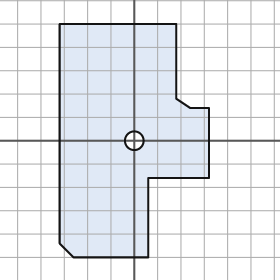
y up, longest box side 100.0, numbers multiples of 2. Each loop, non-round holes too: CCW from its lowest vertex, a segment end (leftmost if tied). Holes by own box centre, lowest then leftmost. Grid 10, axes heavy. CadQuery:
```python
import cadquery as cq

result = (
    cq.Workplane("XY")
    .moveTo(-26.0, -50.0)
    .lineTo(6.0, -50.0)
    .lineTo(6.0, -16.0)
    .lineTo(32.0, -16.0)
    .lineTo(32.0, 14.0)
    .lineTo(24.0, 14.0)
    .lineTo(18.0, 18.0)
    .lineTo(18.0, 50.0)
    .lineTo(-32.0, 50.0)
    .lineTo(-32.0, -44.0)
    .close()
    .moveTo(0.0, 0.0)
    .circle(4.0)
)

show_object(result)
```